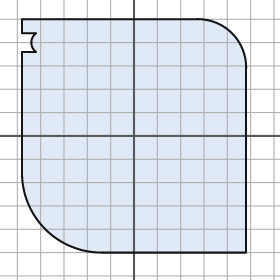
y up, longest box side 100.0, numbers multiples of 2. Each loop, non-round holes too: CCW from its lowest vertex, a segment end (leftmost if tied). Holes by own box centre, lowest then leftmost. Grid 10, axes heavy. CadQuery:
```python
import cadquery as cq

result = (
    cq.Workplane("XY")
    .moveTo(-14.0, -50.0)
    .lineTo(48.0, -50.0)
    .lineTo(48.0, 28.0)
    .threePointArc((42.0, 44.0), (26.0, 50.0))
    .lineTo(-48.0, 50.0)
    .lineTo(-48.0, 44.0)
    .lineTo(-42.0, 44.0)
    .threePointArc((-44.0, 40.0), (-42.0, 36.0))
    .lineTo(-48.0, 36.0)
    .lineTo(-48.0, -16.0)
    .threePointArc((-38.0, -40.0), (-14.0, -50.0))
    .close()
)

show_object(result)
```